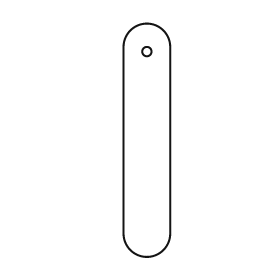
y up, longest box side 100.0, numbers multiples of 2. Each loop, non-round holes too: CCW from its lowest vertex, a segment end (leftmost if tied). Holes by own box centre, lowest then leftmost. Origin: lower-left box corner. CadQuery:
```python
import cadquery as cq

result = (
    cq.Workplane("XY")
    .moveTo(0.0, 10.0)
    .threePointArc((10.0, 0.0), (20.0, 10.0))
    .lineTo(20.0, 90.0)
    .threePointArc((10.0, 100.0), (0.0, 90.0))
    .close()
    .moveTo(10.0, 88.0)
    .circle(2.0)
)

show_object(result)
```